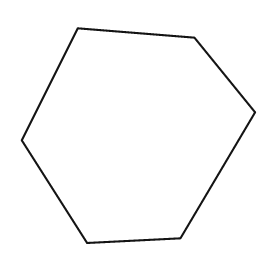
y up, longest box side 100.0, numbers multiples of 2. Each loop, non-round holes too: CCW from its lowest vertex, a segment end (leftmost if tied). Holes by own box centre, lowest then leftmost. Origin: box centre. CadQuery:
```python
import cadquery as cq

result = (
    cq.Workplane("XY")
    .moveTo(-22.0, -46.0)
    .lineTo(18.0, -44.0)
    .lineTo(50.0, 10.0)
    .lineTo(24.0, 42.0)
    .lineTo(-26.0, 46.0)
    .lineTo(-50.0, -2.0)
    .close()
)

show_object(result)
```